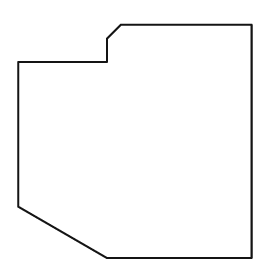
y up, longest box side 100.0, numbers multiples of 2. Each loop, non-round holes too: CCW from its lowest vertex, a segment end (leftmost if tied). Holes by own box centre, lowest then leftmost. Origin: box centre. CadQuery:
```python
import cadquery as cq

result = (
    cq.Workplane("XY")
    .moveTo(-12.0, -50.0)
    .lineTo(50.0, -50.0)
    .lineTo(50.0, 50.0)
    .lineTo(-6.0, 50.0)
    .lineTo(-12.0, 44.0)
    .lineTo(-12.0, 34.0)
    .lineTo(-50.0, 34.0)
    .lineTo(-50.0, -28.0)
    .close()
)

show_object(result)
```